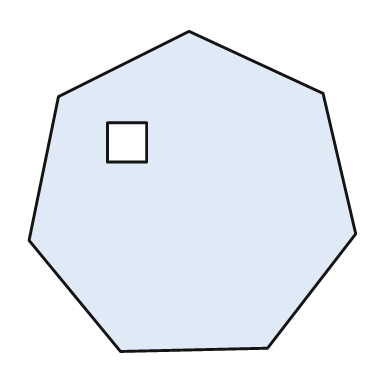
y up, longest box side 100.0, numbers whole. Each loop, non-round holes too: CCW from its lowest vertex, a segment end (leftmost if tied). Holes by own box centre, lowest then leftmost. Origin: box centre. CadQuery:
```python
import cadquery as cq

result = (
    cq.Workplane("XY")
    .moveTo(-22.0, -49.0)
    .lineTo(23.0, -48.0)
    .lineTo(50.0, -13.0)
    .lineTo(40.0, 30.0)
    .lineTo(-1.0, 49.0)
    .lineTo(-41.0, 29.0)
    .lineTo(-50.0, -15.0)
    .close()
    .moveTo(-26.0, 9.0)
    .lineTo(-14.0, 9.0)
    .lineTo(-14.0, 21.0)
    .lineTo(-26.0, 21.0)
    .close()
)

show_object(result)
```